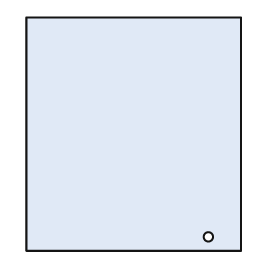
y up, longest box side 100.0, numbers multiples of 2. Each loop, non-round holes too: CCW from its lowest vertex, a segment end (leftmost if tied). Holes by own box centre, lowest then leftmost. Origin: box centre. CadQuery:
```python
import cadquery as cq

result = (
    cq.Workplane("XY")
    .moveTo(-46.0, -50.0)
    .lineTo(46.0, -50.0)
    .lineTo(46.0, 50.0)
    .lineTo(-46.0, 50.0)
    .close()
    .moveTo(32.0, -44.0)
    .circle(2.0)
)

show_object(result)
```